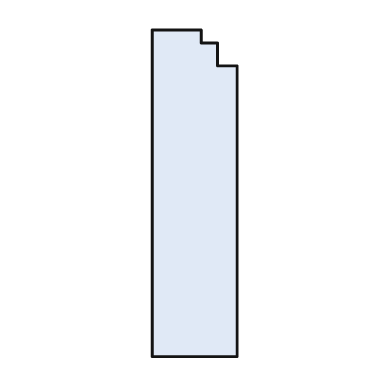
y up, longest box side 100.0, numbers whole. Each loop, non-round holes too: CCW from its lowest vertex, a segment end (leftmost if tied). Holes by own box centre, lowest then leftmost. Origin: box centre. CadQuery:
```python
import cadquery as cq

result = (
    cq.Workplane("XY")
    .moveTo(-13.0, -50.0)
    .lineTo(13.0, -50.0)
    .lineTo(13.0, 39.0)
    .lineTo(7.0, 39.0)
    .lineTo(7.0, 46.0)
    .lineTo(2.0, 46.0)
    .lineTo(2.0, 50.0)
    .lineTo(-13.0, 50.0)
    .close()
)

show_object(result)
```